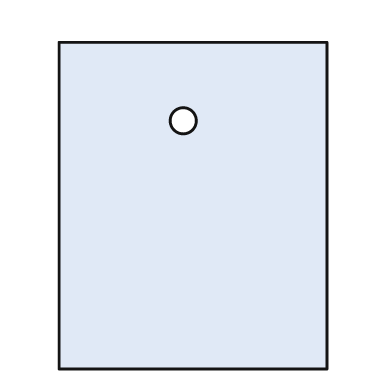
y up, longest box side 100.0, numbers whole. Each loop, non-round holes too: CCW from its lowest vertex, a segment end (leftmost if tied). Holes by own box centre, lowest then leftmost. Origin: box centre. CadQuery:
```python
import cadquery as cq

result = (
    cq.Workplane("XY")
    .moveTo(-41.0, -50.0)
    .lineTo(41.0, -50.0)
    .lineTo(41.0, 50.0)
    .lineTo(-41.0, 50.0)
    .close()
    .moveTo(-3.0, 26.0)
    .circle(4.0)
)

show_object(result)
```